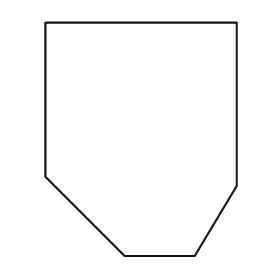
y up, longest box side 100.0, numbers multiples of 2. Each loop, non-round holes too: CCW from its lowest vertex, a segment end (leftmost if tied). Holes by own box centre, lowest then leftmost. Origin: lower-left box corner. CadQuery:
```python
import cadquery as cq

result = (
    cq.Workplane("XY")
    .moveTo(34.0, 0.0)
    .lineTo(64.0, 0.0)
    .lineTo(82.0, 30.0)
    .lineTo(82.0, 100.0)
    .lineTo(0.0, 100.0)
    .lineTo(0.0, 34.0)
    .close()
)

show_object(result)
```